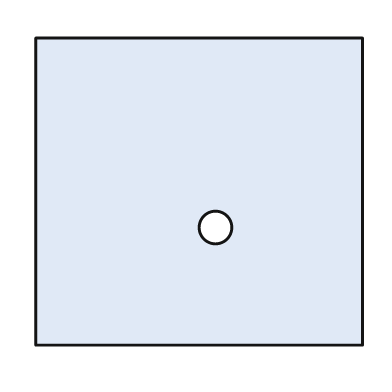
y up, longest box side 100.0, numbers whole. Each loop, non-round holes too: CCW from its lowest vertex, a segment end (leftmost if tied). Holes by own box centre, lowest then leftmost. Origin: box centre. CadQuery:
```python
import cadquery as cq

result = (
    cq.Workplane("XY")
    .moveTo(-50.0, -47.0)
    .lineTo(50.0, -47.0)
    .lineTo(50.0, 47.0)
    .lineTo(-50.0, 47.0)
    .close()
    .moveTo(5.0, -11.0)
    .circle(5.0)
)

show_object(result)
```